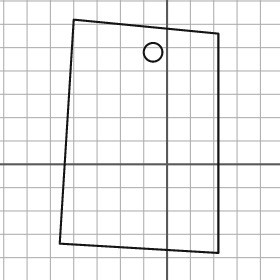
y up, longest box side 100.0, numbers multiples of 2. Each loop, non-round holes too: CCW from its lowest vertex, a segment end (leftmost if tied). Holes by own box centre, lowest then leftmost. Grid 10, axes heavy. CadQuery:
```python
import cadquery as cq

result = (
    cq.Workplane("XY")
    .moveTo(22.0, -38.0)
    .lineTo(22.0, 56.0)
    .lineTo(-40.0, 62.0)
    .lineTo(-46.0, -34.0)
    .close()
    .moveTo(-6.0, 48.0)
    .circle(4.0)
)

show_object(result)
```